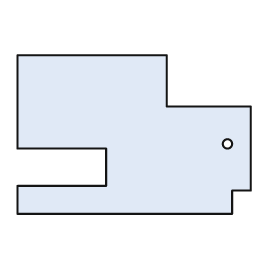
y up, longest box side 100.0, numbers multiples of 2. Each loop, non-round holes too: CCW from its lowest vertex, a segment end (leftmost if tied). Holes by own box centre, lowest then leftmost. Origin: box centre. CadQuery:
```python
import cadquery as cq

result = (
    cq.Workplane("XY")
    .moveTo(-50.0, -34.0)
    .lineTo(42.0, -34.0)
    .lineTo(42.0, -24.0)
    .lineTo(50.0, -24.0)
    .lineTo(50.0, 12.0)
    .lineTo(14.0, 12.0)
    .lineTo(14.0, 34.0)
    .lineTo(-50.0, 34.0)
    .lineTo(-50.0, -6.0)
    .lineTo(-12.0, -6.0)
    .lineTo(-12.0, -22.0)
    .lineTo(-50.0, -22.0)
    .close()
    .moveTo(40.0, -4.0)
    .circle(2.0)
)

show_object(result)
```